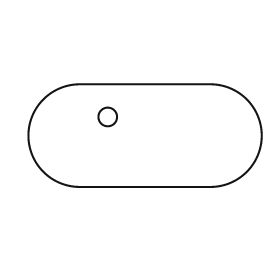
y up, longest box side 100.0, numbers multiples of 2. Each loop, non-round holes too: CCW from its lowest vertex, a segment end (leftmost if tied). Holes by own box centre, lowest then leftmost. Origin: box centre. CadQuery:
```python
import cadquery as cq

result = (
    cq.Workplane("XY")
    .moveTo(-28.0, -22.0)
    .lineTo(28.0, -22.0)
    .threePointArc((50.0, 0.0), (28.0, 22.0))
    .lineTo(-28.0, 22.0)
    .threePointArc((-50.0, 0.0), (-28.0, -22.0))
    .close()
    .moveTo(-16.0, 8.0)
    .circle(4.0)
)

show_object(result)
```